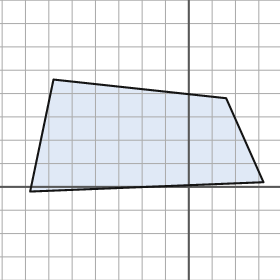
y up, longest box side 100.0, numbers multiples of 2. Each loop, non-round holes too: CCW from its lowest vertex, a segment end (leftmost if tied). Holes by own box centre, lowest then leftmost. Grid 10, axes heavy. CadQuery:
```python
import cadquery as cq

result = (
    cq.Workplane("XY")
    .moveTo(-68.0, -2.0)
    .lineTo(32.0, 2.0)
    .lineTo(16.0, 38.0)
    .lineTo(-58.0, 46.0)
    .close()
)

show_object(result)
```